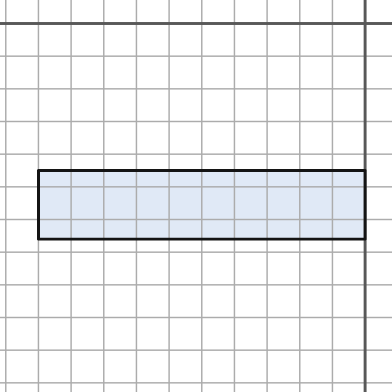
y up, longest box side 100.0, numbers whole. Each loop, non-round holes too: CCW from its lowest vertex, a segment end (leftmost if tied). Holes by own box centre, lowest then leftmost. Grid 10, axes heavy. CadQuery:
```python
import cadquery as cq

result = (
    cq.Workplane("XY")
    .moveTo(-100.0, -66.0)
    .lineTo(0.0, -66.0)
    .lineTo(0.0, -45.0)
    .lineTo(-100.0, -45.0)
    .close()
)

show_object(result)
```